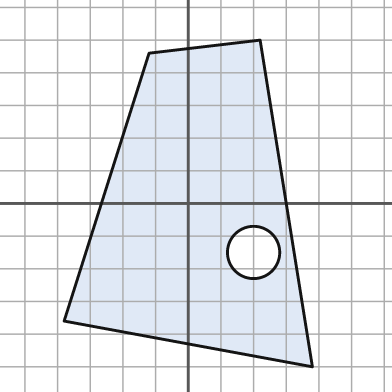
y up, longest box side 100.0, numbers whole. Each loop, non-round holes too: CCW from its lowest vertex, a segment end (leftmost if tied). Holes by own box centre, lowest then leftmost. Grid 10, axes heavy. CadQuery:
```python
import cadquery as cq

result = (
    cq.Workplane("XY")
    .moveTo(38.0, -50.0)
    .lineTo(22.0, 50.0)
    .lineTo(-12.0, 46.0)
    .lineTo(-38.0, -36.0)
    .close()
    .moveTo(20.0, -15.0)
    .circle(8.0)
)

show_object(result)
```